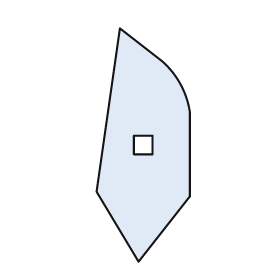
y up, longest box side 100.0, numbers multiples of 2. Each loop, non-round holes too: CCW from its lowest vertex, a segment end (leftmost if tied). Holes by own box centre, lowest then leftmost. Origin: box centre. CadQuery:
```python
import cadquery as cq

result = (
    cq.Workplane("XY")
    .moveTo(-2.0, -50.0)
    .lineTo(20.0, -22.0)
    .lineTo(20.0, 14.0)
    .threePointArc((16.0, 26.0), (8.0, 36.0))
    .lineTo(-10.0, 50.0)
    .lineTo(-20.0, -20.0)
    .close()
    .moveTo(-4.0, -4.0)
    .lineTo(4.0, -4.0)
    .lineTo(4.0, 4.0)
    .lineTo(-4.0, 4.0)
    .close()
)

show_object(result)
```